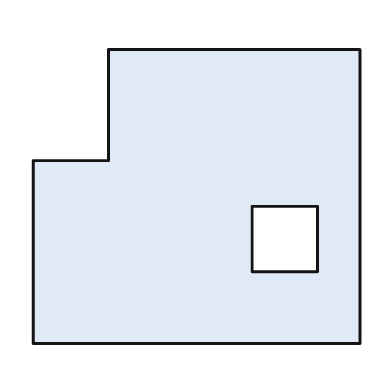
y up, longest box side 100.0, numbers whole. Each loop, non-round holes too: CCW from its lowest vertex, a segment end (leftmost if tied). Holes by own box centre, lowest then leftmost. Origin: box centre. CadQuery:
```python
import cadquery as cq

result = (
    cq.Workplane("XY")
    .moveTo(-50.0, -45.0)
    .lineTo(50.0, -45.0)
    .lineTo(50.0, 45.0)
    .lineTo(-27.0, 45.0)
    .lineTo(-27.0, 11.0)
    .lineTo(-50.0, 11.0)
    .close()
    .moveTo(17.0, -23.0)
    .lineTo(37.0, -23.0)
    .lineTo(37.0, -3.0)
    .lineTo(17.0, -3.0)
    .close()
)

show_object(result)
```